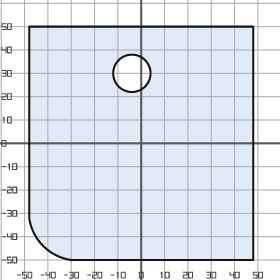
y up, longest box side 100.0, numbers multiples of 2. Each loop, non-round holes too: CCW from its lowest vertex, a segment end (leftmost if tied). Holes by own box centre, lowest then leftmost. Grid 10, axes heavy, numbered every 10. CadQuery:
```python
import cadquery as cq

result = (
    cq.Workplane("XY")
    .moveTo(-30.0, -50.0)
    .lineTo(48.0, -50.0)
    .lineTo(48.0, 50.0)
    .lineTo(-48.0, 50.0)
    .lineTo(-48.0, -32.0)
    .threePointArc((-42.0, -44.0), (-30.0, -50.0))
    .close()
    .moveTo(-4.0, 30.0)
    .circle(8.0)
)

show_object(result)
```